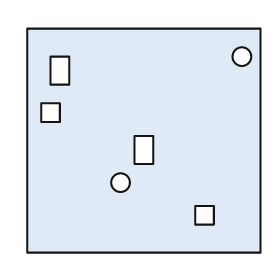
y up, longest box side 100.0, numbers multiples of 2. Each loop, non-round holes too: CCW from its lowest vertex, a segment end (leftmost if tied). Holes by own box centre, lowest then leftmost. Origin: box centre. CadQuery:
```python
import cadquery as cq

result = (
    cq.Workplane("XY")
    .moveTo(-50.0, -48.0)
    .lineTo(50.0, -48.0)
    .lineTo(50.0, 48.0)
    .lineTo(-50.0, 48.0)
    .close()
    .moveTo(22.0, -36.0)
    .lineTo(30.0, -36.0)
    .lineTo(30.0, -28.0)
    .lineTo(22.0, -28.0)
    .close()
    .moveTo(-10.0, -18.0)
    .circle(4.0)
    .moveTo(-4.0, -10.0)
    .lineTo(4.0, -10.0)
    .lineTo(4.0, 2.0)
    .lineTo(-4.0, 2.0)
    .close()
    .moveTo(-44.0, 8.0)
    .lineTo(-36.0, 8.0)
    .lineTo(-36.0, 16.0)
    .lineTo(-44.0, 16.0)
    .close()
    .moveTo(-40.0, 24.0)
    .lineTo(-32.0, 24.0)
    .lineTo(-32.0, 36.0)
    .lineTo(-40.0, 36.0)
    .close()
    .moveTo(42.0, 36.0)
    .circle(4.0)
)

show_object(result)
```